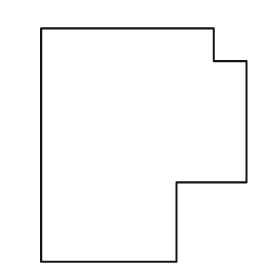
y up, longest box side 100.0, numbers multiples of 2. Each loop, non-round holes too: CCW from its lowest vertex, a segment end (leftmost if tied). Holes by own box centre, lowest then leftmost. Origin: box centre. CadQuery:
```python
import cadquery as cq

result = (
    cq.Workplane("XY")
    .moveTo(-44.0, -50.0)
    .lineTo(14.0, -50.0)
    .lineTo(14.0, -16.0)
    .lineTo(44.0, -16.0)
    .lineTo(44.0, 36.0)
    .lineTo(30.0, 36.0)
    .lineTo(30.0, 50.0)
    .lineTo(-44.0, 50.0)
    .close()
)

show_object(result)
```